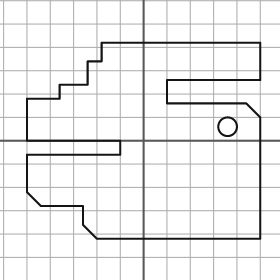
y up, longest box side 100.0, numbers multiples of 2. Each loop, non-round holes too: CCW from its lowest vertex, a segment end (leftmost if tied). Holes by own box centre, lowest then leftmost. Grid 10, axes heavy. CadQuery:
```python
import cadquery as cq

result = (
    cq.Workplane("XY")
    .moveTo(-20.0, -42.0)
    .lineTo(50.0, -42.0)
    .lineTo(50.0, 10.0)
    .lineTo(44.0, 16.0)
    .lineTo(10.0, 16.0)
    .lineTo(10.0, 26.0)
    .lineTo(50.0, 26.0)
    .lineTo(50.0, 42.0)
    .lineTo(-18.0, 42.0)
    .lineTo(-18.0, 34.0)
    .lineTo(-24.0, 34.0)
    .lineTo(-24.0, 24.0)
    .lineTo(-36.0, 24.0)
    .lineTo(-36.0, 18.0)
    .lineTo(-50.0, 18.0)
    .lineTo(-50.0, 0.0)
    .lineTo(-10.0, 0.0)
    .lineTo(-10.0, -6.0)
    .lineTo(-50.0, -6.0)
    .lineTo(-50.0, -22.0)
    .lineTo(-44.0, -28.0)
    .lineTo(-26.0, -28.0)
    .lineTo(-26.0, -36.0)
    .close()
    .moveTo(36.0, 6.0)
    .circle(4.0)
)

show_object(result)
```